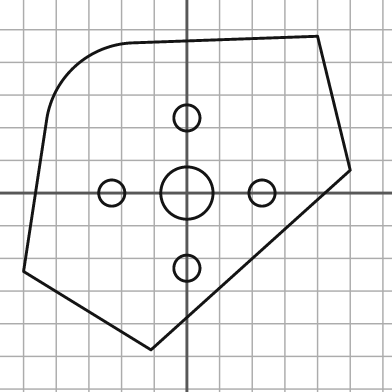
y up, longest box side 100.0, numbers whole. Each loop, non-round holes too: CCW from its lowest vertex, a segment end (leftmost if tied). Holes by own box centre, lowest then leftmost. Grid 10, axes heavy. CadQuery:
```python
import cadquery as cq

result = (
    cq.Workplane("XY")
    .moveTo(-11.0, -48.0)
    .lineTo(50.0, 7.0)
    .lineTo(40.0, 48.0)
    .lineTo(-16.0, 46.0)
    .threePointArc((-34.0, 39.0), (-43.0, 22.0))
    .lineTo(-50.0, -24.0)
    .close()
    .moveTo(0.0, -23.0)
    .circle(4.0)
    .moveTo(-23.0, 0.0)
    .circle(4.0)
    .moveTo(0.0, 0.0)
    .circle(8.0)
    .moveTo(23.0, 0.0)
    .circle(4.0)
    .moveTo(0.0, 23.0)
    .circle(4.0)
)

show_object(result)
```